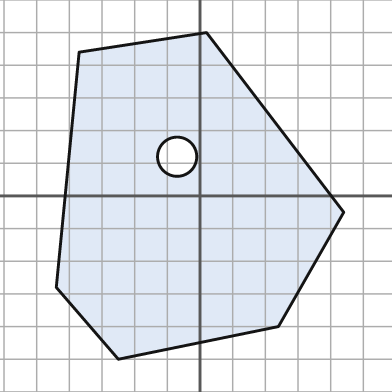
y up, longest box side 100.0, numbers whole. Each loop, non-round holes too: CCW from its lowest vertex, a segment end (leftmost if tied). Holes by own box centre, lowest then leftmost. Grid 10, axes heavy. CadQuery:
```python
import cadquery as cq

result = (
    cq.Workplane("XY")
    .moveTo(-25.0, -50.0)
    .lineTo(24.0, -40.0)
    .lineTo(44.0, -5.0)
    .lineTo(2.0, 50.0)
    .lineTo(-37.0, 44.0)
    .lineTo(-44.0, -28.0)
    .close()
    .moveTo(-7.0, 12.0)
    .circle(6.0)
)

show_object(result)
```